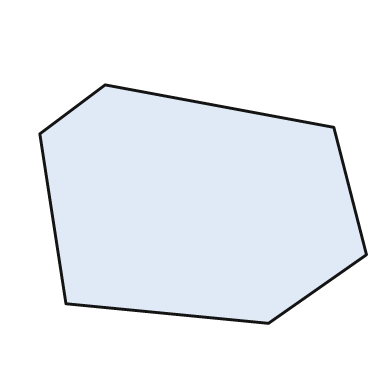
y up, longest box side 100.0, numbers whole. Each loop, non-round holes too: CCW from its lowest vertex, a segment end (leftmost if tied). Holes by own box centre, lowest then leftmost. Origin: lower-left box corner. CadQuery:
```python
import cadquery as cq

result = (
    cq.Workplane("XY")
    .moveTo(70.0, 0.0)
    .lineTo(100.0, 21.0)
    .lineTo(90.0, 60.0)
    .lineTo(20.0, 73.0)
    .lineTo(0.0, 58.0)
    .lineTo(8.0, 6.0)
    .close()
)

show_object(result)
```